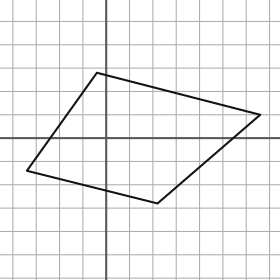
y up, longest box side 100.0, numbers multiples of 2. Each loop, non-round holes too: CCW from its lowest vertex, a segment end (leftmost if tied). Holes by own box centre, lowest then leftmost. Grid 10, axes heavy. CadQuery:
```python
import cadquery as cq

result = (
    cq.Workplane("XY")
    .moveTo(22.0, -28.0)
    .lineTo(66.0, 10.0)
    .lineTo(-4.0, 28.0)
    .lineTo(-34.0, -14.0)
    .close()
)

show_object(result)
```